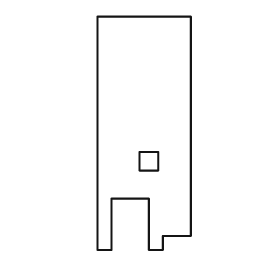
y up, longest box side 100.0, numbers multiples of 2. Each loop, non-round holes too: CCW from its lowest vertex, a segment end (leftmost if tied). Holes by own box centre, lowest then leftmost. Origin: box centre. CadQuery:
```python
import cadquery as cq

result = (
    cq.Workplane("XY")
    .moveTo(-20.0, -50.0)
    .lineTo(-14.0, -50.0)
    .lineTo(-14.0, -28.0)
    .lineTo(2.0, -28.0)
    .lineTo(2.0, -50.0)
    .lineTo(8.0, -50.0)
    .lineTo(8.0, -44.0)
    .lineTo(20.0, -44.0)
    .lineTo(20.0, 50.0)
    .lineTo(-20.0, 50.0)
    .close()
    .moveTo(-2.0, -16.0)
    .lineTo(6.0, -16.0)
    .lineTo(6.0, -8.0)
    .lineTo(-2.0, -8.0)
    .close()
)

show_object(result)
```